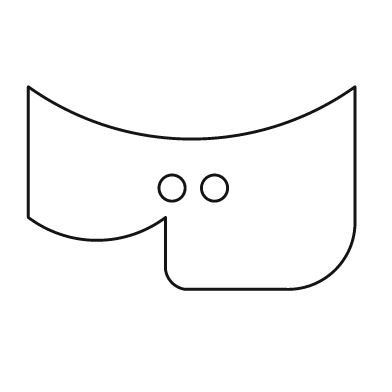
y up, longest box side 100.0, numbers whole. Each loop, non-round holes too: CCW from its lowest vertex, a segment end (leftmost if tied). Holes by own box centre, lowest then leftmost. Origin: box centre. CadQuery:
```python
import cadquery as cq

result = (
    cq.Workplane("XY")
    .moveTo(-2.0, -31.0)
    .lineTo(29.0, -31.0)
    .threePointArc((44.0, -25.0), (50.0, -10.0))
    .lineTo(50.0, 31.0)
    .threePointArc((0.0, 15.0), (-50.0, 31.0))
    .lineTo(-50.0, -9.0)
    .threePointArc((-29.0, -16.0), (-8.0, -9.0))
    .lineTo(-8.0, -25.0)
    .threePointArc((-6.0, -29.0), (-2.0, -31.0))
    .close()
    .moveTo(-6.0, 0.0)
    .circle(4.0)
    .moveTo(7.0, 0.0)
    .circle(4.0)
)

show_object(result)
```